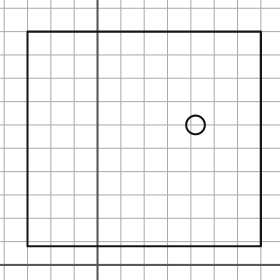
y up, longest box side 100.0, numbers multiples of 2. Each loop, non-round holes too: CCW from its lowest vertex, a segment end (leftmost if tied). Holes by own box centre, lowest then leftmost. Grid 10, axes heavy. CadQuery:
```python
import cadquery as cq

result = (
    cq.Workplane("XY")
    .moveTo(-30.0, 8.0)
    .lineTo(70.0, 8.0)
    .lineTo(70.0, 100.0)
    .lineTo(-30.0, 100.0)
    .close()
    .moveTo(42.0, 60.0)
    .circle(4.0)
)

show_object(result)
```